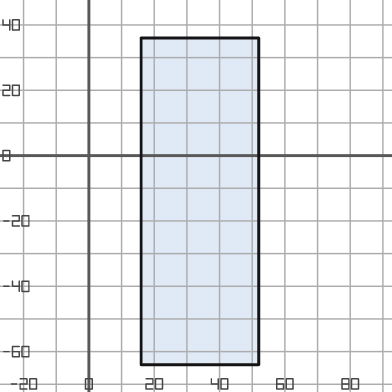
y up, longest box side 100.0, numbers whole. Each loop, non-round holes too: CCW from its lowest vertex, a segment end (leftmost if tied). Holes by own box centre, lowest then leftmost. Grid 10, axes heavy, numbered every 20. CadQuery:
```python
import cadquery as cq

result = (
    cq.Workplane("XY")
    .moveTo(16.0, -64.0)
    .lineTo(52.0, -64.0)
    .lineTo(52.0, 36.0)
    .lineTo(16.0, 36.0)
    .close()
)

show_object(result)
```